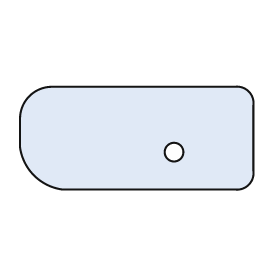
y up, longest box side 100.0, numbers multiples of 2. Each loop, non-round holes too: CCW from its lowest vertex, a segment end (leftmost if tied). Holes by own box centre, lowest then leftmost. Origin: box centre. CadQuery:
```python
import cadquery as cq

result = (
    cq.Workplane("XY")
    .moveTo(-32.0, -22.0)
    .lineTo(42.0, -22.0)
    .threePointArc((48.0, -20.0), (50.0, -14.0))
    .lineTo(50.0, 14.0)
    .threePointArc((48.0, 20.0), (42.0, 22.0))
    .lineTo(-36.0, 22.0)
    .threePointArc((-46.0, 18.0), (-50.0, 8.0))
    .lineTo(-50.0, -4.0)
    .threePointArc((-44.0, -16.0), (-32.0, -22.0))
    .close()
    .moveTo(16.0, -6.0)
    .circle(4.0)
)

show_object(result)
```